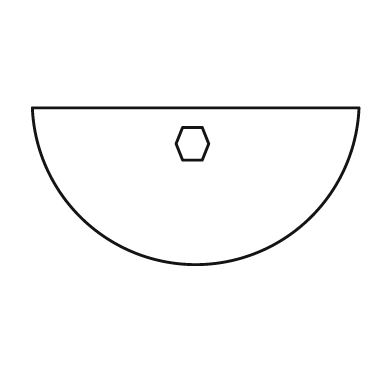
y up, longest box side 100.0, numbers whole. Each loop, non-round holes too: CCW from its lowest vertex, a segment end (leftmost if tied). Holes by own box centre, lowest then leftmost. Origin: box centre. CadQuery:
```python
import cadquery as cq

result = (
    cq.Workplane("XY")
    .moveTo(-50.0, 24.0)
    .threePointArc((0.0, -24.0), (50.0, 24.0))
    .close()
    .moveTo(-4.0, 8.0)
    .lineTo(2.0, 8.0)
    .lineTo(4.0, 13.0)
    .lineTo(2.0, 18.0)
    .lineTo(-4.0, 18.0)
    .lineTo(-6.0, 13.0)
    .close()
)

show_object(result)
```